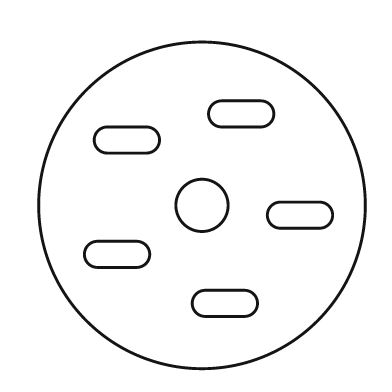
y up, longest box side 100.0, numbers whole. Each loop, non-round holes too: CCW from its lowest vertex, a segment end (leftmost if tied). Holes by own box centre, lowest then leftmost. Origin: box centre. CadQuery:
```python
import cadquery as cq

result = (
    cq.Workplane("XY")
    .moveTo(0.0, 0.0)
    .circle(50.0)
    .moveTo(1.0, -34.0)
    .lineTo(13.0, -34.0)
    .threePointArc((17.0, -30.0), (13.0, -26.0))
    .lineTo(1.0, -26.0)
    .threePointArc((-3.0, -30.0), (1.0, -34.0))
    .close()
    .moveTo(-32.0, -19.0)
    .lineTo(-20.0, -19.0)
    .threePointArc((-16.0, -15.0), (-20.0, -11.0))
    .lineTo(-32.0, -11.0)
    .threePointArc((-36.0, -15.0), (-32.0, -19.0))
    .close()
    .moveTo(24.0, -7.0)
    .lineTo(36.0, -7.0)
    .threePointArc((40.0, -3.0), (36.0, 1.0))
    .lineTo(24.0, 1.0)
    .threePointArc((20.0, -3.0), (24.0, -7.0))
    .close()
    .moveTo(0.0, 0.0)
    .circle(8.0)
    .moveTo(-29.0, 16.0)
    .lineTo(-17.0, 16.0)
    .threePointArc((-13.0, 20.0), (-17.0, 24.0))
    .lineTo(-29.0, 24.0)
    .threePointArc((-33.0, 20.0), (-29.0, 16.0))
    .close()
    .moveTo(6.0, 24.0)
    .lineTo(18.0, 24.0)
    .threePointArc((22.0, 28.0), (18.0, 32.0))
    .lineTo(6.0, 32.0)
    .threePointArc((2.0, 28.0), (6.0, 24.0))
    .close()
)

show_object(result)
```